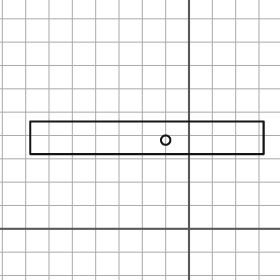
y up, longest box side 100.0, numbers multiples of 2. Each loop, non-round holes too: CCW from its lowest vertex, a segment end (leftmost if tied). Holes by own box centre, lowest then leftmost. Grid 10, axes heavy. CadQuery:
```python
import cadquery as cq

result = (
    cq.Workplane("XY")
    .moveTo(-68.0, 32.0)
    .lineTo(32.0, 32.0)
    .lineTo(32.0, 46.0)
    .lineTo(-68.0, 46.0)
    .close()
    .moveTo(-10.0, 38.0)
    .circle(2.0)
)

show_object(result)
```